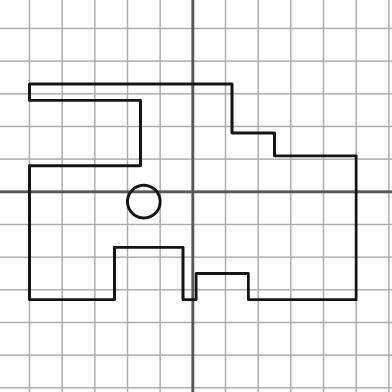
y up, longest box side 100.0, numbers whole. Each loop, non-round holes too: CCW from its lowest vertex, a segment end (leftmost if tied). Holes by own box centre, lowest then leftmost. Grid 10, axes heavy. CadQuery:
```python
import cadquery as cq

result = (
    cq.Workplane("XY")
    .moveTo(-50.0, -33.0)
    .lineTo(-24.0, -33.0)
    .lineTo(-24.0, -17.0)
    .lineTo(-3.0, -17.0)
    .lineTo(-3.0, -33.0)
    .lineTo(1.0, -33.0)
    .lineTo(1.0, -25.0)
    .lineTo(17.0, -25.0)
    .lineTo(17.0, -33.0)
    .lineTo(50.0, -33.0)
    .lineTo(50.0, 11.0)
    .lineTo(25.0, 11.0)
    .lineTo(25.0, 18.0)
    .lineTo(12.0, 18.0)
    .lineTo(12.0, 33.0)
    .lineTo(-50.0, 33.0)
    .lineTo(-50.0, 28.0)
    .lineTo(-16.0, 28.0)
    .lineTo(-16.0, 8.0)
    .lineTo(-50.0, 8.0)
    .close()
    .moveTo(-15.0, -3.0)
    .circle(5.0)
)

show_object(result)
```